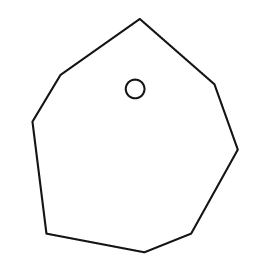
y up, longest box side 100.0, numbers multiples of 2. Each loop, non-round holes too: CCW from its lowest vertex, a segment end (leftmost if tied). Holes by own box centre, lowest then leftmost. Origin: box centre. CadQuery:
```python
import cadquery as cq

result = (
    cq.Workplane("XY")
    .moveTo(4.0, -50.0)
    .lineTo(24.0, -42.0)
    .lineTo(44.0, -6.0)
    .lineTo(34.0, 22.0)
    .lineTo(2.0, 50.0)
    .lineTo(-32.0, 26.0)
    .lineTo(-44.0, 6.0)
    .lineTo(-38.0, -42.0)
    .close()
    .moveTo(0.0, 20.0)
    .circle(4.0)
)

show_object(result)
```